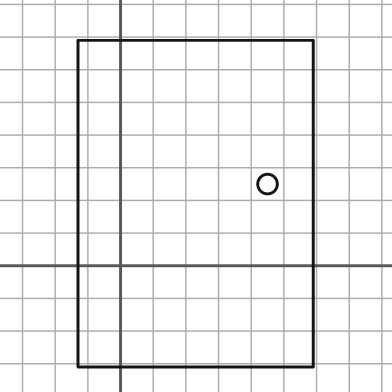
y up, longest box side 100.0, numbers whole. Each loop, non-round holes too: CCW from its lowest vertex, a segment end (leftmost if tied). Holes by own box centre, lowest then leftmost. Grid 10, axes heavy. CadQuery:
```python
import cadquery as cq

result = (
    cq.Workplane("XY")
    .moveTo(-13.0, -31.0)
    .lineTo(59.0, -31.0)
    .lineTo(59.0, 69.0)
    .lineTo(-13.0, 69.0)
    .close()
    .moveTo(45.0, 25.0)
    .circle(3.0)
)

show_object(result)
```